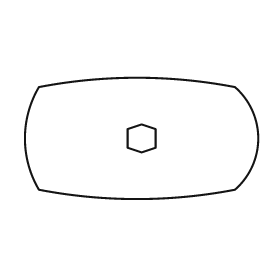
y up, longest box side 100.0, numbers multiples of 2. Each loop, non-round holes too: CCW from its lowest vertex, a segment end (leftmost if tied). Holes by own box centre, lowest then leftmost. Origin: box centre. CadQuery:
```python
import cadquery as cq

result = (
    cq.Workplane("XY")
    .moveTo(-44.0, -22.0)
    .threePointArc((-2.0, -26.0), (40.0, -22.0))
    .threePointArc((50.0, 0.0), (40.0, 22.0))
    .threePointArc((-2.0, 26.0), (-44.0, 22.0))
    .threePointArc((-50.0, 0.0), (-44.0, -22.0))
    .close()
    .moveTo(0.0, -6.0)
    .lineTo(6.0, -4.0)
    .lineTo(6.0, 4.0)
    .lineTo(0.0, 6.0)
    .lineTo(-6.0, 4.0)
    .lineTo(-6.0, -4.0)
    .close()
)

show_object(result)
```